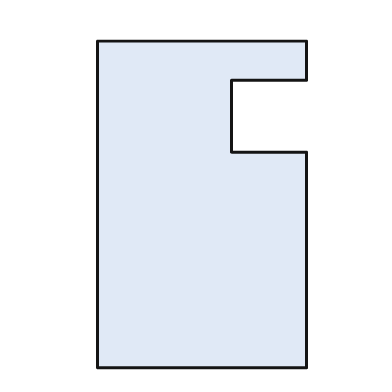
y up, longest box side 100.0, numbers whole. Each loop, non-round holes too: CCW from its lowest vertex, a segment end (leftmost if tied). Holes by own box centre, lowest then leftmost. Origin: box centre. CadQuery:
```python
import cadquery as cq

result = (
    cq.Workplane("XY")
    .moveTo(-32.0, -50.0)
    .lineTo(32.0, -50.0)
    .lineTo(32.0, 16.0)
    .lineTo(9.0, 16.0)
    .lineTo(9.0, 38.0)
    .lineTo(32.0, 38.0)
    .lineTo(32.0, 50.0)
    .lineTo(-32.0, 50.0)
    .close()
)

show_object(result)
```